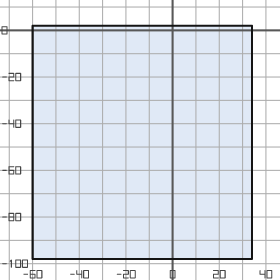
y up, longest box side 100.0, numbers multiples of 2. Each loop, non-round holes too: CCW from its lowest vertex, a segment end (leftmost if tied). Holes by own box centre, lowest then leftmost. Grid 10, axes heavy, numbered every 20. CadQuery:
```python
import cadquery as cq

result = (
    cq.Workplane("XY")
    .moveTo(-60.0, -98.0)
    .lineTo(34.0, -98.0)
    .lineTo(34.0, 2.0)
    .lineTo(-60.0, 2.0)
    .close()
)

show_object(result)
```